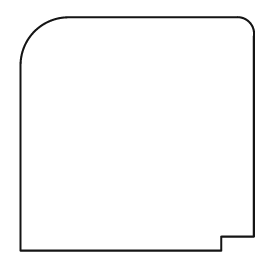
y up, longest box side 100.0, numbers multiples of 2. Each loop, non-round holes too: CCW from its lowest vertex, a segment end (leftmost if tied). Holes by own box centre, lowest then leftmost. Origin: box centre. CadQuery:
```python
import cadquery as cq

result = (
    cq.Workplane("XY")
    .moveTo(-50.0, -50.0)
    .lineTo(36.0, -50.0)
    .lineTo(36.0, -44.0)
    .lineTo(50.0, -44.0)
    .lineTo(50.0, 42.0)
    .threePointArc((48.0, 48.0), (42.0, 50.0))
    .lineTo(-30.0, 50.0)
    .threePointArc((-44.0, 44.0), (-50.0, 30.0))
    .close()
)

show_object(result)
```